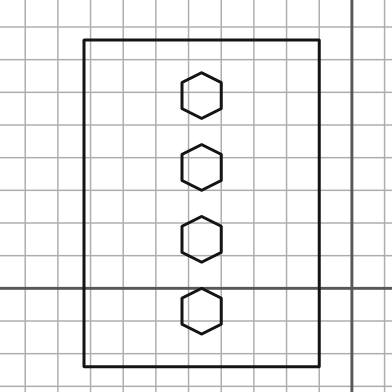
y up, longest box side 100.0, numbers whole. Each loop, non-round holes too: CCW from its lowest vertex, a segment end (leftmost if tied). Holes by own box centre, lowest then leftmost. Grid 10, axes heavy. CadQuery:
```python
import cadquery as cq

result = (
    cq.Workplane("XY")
    .moveTo(-82.0, -24.0)
    .lineTo(-10.0, -24.0)
    .lineTo(-10.0, 76.0)
    .lineTo(-82.0, 76.0)
    .close()
    .moveTo(-46.0, -14.0)
    .lineTo(-40.0, -11.0)
    .lineTo(-40.0, -3.0)
    .lineTo(-46.0, 0.0)
    .lineTo(-52.0, -3.0)
    .lineTo(-52.0, -11.0)
    .close()
    .moveTo(-46.0, 8.0)
    .lineTo(-40.0, 11.0)
    .lineTo(-40.0, 19.0)
    .lineTo(-46.0, 22.0)
    .lineTo(-52.0, 19.0)
    .lineTo(-52.0, 11.0)
    .close()
    .moveTo(-46.0, 30.0)
    .lineTo(-40.0, 33.0)
    .lineTo(-40.0, 41.0)
    .lineTo(-46.0, 44.0)
    .lineTo(-52.0, 41.0)
    .lineTo(-52.0, 33.0)
    .close()
    .moveTo(-46.0, 52.0)
    .lineTo(-40.0, 55.0)
    .lineTo(-40.0, 63.0)
    .lineTo(-46.0, 66.0)
    .lineTo(-52.0, 63.0)
    .lineTo(-52.0, 55.0)
    .close()
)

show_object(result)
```